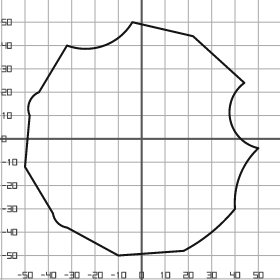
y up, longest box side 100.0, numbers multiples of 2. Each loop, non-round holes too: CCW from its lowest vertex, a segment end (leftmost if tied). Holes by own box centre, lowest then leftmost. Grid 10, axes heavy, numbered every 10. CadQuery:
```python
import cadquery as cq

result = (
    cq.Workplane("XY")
    .moveTo(-10.0, -50.0)
    .lineTo(18.0, -48.0)
    .threePointArc((30.0, -40.0), (40.0, -30.0))
    .threePointArc((42.0, -16.0), (50.0, -4.0))
    .threePointArc((38.0, 8.0), (44.0, 24.0))
    .lineTo(22.0, 44.0)
    .lineTo(-4.0, 50.0)
    .threePointArc((-16.0, 40.0), (-32.0, 40.0))
    .lineTo(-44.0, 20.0)
    .threePointArc((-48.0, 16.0), (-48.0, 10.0))
    .lineTo(-50.0, -12.0)
    .lineTo(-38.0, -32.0)
    .threePointArc((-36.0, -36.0), (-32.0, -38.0))
    .close()
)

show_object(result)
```